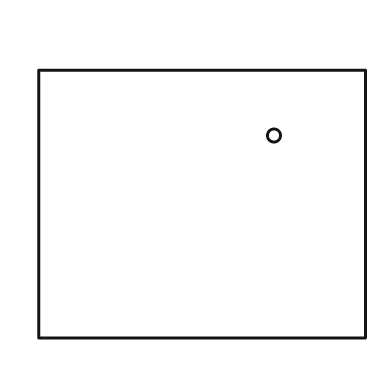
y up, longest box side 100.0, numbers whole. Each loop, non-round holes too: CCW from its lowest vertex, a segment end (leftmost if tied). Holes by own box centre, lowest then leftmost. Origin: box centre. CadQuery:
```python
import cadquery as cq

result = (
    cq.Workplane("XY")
    .moveTo(-50.0, -41.0)
    .lineTo(50.0, -41.0)
    .lineTo(50.0, 41.0)
    .lineTo(-50.0, 41.0)
    .close()
    .moveTo(22.0, 21.0)
    .circle(2.0)
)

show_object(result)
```